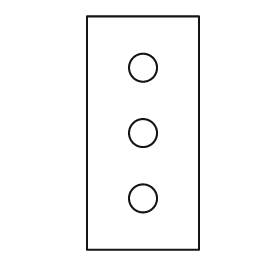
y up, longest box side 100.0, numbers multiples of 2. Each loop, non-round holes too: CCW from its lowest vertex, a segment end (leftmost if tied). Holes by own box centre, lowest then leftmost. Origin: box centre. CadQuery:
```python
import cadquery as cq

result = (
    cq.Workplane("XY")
    .moveTo(-24.0, -50.0)
    .lineTo(24.0, -50.0)
    .lineTo(24.0, 50.0)
    .lineTo(-24.0, 50.0)
    .close()
    .moveTo(0.0, -28.0)
    .circle(6.0)
    .moveTo(0.0, 0.0)
    .circle(6.0)
    .moveTo(0.0, 28.0)
    .circle(6.0)
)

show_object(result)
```